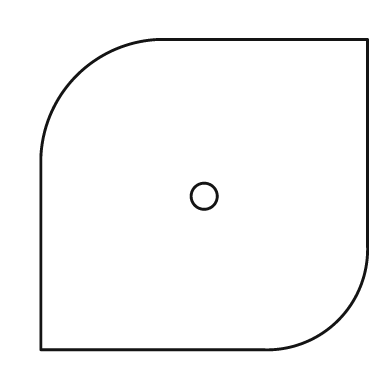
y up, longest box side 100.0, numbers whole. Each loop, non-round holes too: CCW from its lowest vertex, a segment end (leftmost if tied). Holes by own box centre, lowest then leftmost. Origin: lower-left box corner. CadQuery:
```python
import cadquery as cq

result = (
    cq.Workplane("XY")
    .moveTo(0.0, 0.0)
    .lineTo(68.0, 0.0)
    .threePointArc((91.0, 9.0), (100.0, 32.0))
    .lineTo(100.0, 95.0)
    .lineTo(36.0, 95.0)
    .threePointArc((11.0, 84.0), (0.0, 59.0))
    .close()
    .moveTo(50.0, 47.0)
    .circle(4.0)
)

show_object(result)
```